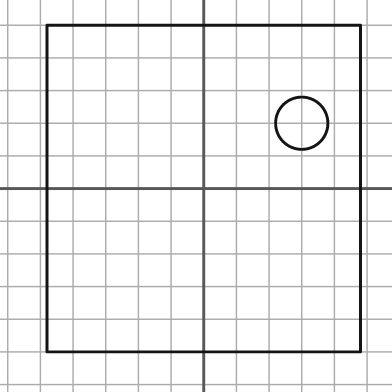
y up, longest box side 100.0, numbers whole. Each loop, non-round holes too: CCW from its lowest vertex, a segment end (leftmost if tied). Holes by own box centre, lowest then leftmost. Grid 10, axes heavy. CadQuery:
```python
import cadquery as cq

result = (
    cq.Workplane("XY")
    .moveTo(-48.0, -50.0)
    .lineTo(48.0, -50.0)
    .lineTo(48.0, 50.0)
    .lineTo(-48.0, 50.0)
    .close()
    .moveTo(30.0, 20.0)
    .circle(8.0)
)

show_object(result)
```